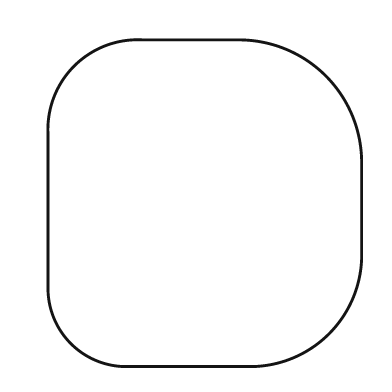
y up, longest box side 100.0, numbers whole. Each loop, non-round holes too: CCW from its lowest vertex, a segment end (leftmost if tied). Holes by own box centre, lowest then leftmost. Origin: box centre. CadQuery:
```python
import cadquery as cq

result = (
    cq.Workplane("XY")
    .moveTo(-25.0, -50.0)
    .lineTo(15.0, -50.0)
    .threePointArc((38.0, -40.0), (48.0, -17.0))
    .lineTo(48.0, 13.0)
    .threePointArc((37.0, 39.0), (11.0, 50.0))
    .lineTo(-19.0, 50.0)
    .threePointArc((-40.0, 42.0), (-48.0, 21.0))
    .lineTo(-48.0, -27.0)
    .threePointArc((-41.0, -43.0), (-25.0, -50.0))
    .close()
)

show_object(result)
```